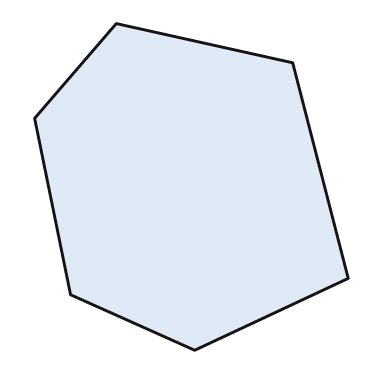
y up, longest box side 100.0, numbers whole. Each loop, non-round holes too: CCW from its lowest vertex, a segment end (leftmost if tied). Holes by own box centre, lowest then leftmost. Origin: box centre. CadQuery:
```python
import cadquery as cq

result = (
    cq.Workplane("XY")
    .moveTo(1.0, -50.0)
    .lineTo(48.0, -28.0)
    .lineTo(31.0, 38.0)
    .lineTo(-23.0, 50.0)
    .lineTo(-48.0, 21.0)
    .lineTo(-37.0, -33.0)
    .close()
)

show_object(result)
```